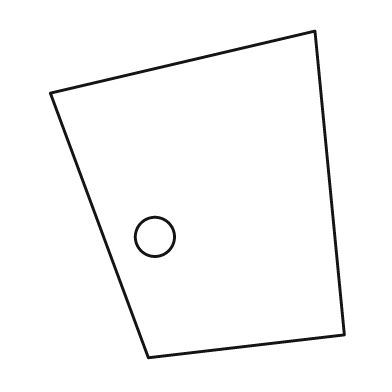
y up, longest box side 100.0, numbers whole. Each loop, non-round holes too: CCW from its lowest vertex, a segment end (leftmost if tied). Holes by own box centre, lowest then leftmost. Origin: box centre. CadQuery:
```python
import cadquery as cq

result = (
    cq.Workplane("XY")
    .moveTo(-15.0, -50.0)
    .lineTo(45.0, -43.0)
    .lineTo(36.0, 50.0)
    .lineTo(-45.0, 31.0)
    .close()
    .moveTo(-13.0, -13.0)
    .circle(6.0)
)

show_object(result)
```